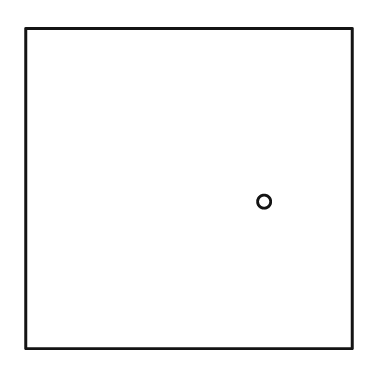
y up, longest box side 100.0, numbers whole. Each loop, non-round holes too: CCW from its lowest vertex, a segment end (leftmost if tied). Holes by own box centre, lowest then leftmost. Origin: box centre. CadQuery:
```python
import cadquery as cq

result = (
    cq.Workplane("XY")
    .moveTo(-50.0, -49.0)
    .lineTo(50.0, -49.0)
    .lineTo(50.0, 49.0)
    .lineTo(-50.0, 49.0)
    .close()
    .moveTo(23.0, -4.0)
    .circle(2.0)
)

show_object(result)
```